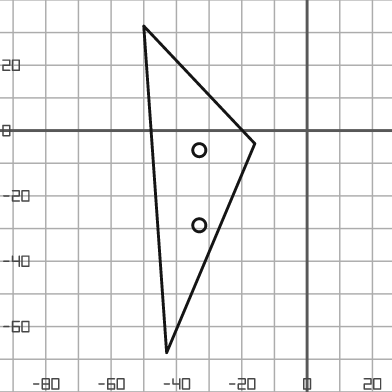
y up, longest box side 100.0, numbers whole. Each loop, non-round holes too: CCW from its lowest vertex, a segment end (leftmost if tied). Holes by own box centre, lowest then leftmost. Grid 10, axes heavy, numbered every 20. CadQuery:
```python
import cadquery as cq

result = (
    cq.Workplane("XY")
    .moveTo(-43.0, -68.0)
    .lineTo(-16.0, -4.0)
    .lineTo(-50.0, 32.0)
    .close()
    .moveTo(-33.0, -29.0)
    .circle(2.0)
    .moveTo(-33.0, -6.0)
    .circle(2.0)
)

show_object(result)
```